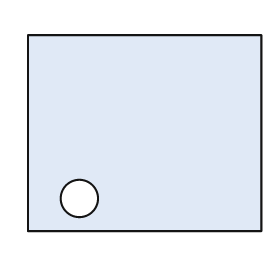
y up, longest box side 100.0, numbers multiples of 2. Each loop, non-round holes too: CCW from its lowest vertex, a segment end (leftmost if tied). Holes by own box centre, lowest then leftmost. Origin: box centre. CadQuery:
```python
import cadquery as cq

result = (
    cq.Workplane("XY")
    .moveTo(-50.0, -42.0)
    .lineTo(50.0, -42.0)
    .lineTo(50.0, 42.0)
    .lineTo(-50.0, 42.0)
    .close()
    .moveTo(-28.0, -28.0)
    .circle(8.0)
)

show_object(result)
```